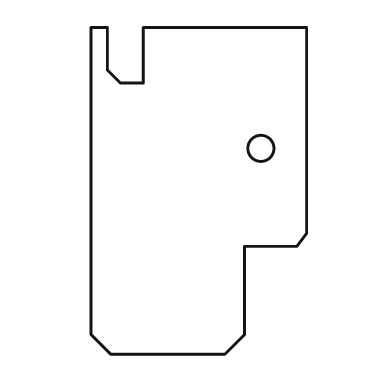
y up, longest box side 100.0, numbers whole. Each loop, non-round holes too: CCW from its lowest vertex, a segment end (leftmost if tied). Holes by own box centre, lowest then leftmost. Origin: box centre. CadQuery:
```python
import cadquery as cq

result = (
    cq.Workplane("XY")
    .moveTo(-27.0, -50.0)
    .lineTo(8.0, -50.0)
    .lineTo(14.0, -44.0)
    .lineTo(14.0, -17.0)
    .lineTo(30.0, -17.0)
    .lineTo(33.0, -13.0)
    .lineTo(33.0, 50.0)
    .lineTo(-17.0, 50.0)
    .lineTo(-17.0, 33.0)
    .lineTo(-24.0, 33.0)
    .lineTo(-28.0, 37.0)
    .lineTo(-28.0, 50.0)
    .lineTo(-33.0, 50.0)
    .lineTo(-33.0, -44.0)
    .close()
    .moveTo(19.0, 13.0)
    .circle(4.0)
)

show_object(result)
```